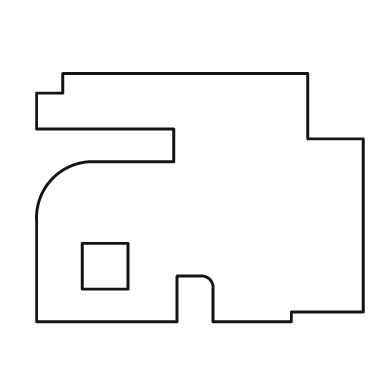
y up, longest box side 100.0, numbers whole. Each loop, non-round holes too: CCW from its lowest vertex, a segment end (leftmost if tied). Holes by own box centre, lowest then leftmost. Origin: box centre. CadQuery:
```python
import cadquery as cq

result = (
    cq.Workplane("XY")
    .moveTo(-50.0, -38.0)
    .lineTo(-7.0, -38.0)
    .lineTo(-7.0, -24.0)
    .lineTo(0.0, -24.0)
    .threePointArc((3.0, -25.0), (4.0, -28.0))
    .lineTo(4.0, -38.0)
    .lineTo(28.0, -38.0)
    .lineTo(28.0, -35.0)
    .lineTo(50.0, -35.0)
    .lineTo(50.0, 18.0)
    .lineTo(33.0, 18.0)
    .lineTo(33.0, 38.0)
    .lineTo(-42.0, 38.0)
    .lineTo(-42.0, 32.0)
    .lineTo(-50.0, 32.0)
    .lineTo(-50.0, 21.0)
    .lineTo(-8.0, 21.0)
    .lineTo(-8.0, 11.0)
    .lineTo(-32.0, 11.0)
    .threePointArc((-45.0, 6.0), (-50.0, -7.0))
    .close()
    .moveTo(-36.0, -28.0)
    .lineTo(-22.0, -28.0)
    .lineTo(-22.0, -14.0)
    .lineTo(-36.0, -14.0)
    .close()
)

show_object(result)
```